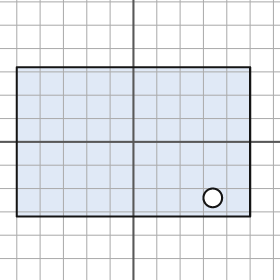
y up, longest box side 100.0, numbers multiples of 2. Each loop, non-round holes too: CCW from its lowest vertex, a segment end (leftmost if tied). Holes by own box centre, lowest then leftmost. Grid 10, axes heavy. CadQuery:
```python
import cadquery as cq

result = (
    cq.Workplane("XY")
    .moveTo(-50.0, -32.0)
    .lineTo(50.0, -32.0)
    .lineTo(50.0, 32.0)
    .lineTo(-50.0, 32.0)
    .close()
    .moveTo(34.0, -24.0)
    .circle(4.0)
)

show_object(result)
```